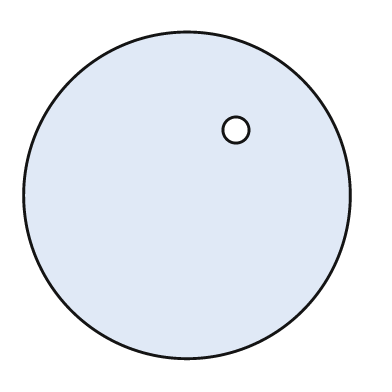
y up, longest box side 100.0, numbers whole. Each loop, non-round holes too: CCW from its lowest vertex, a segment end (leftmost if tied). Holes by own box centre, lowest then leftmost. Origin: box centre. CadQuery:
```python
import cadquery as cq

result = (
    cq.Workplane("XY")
    .moveTo(0.0, 0.0)
    .circle(50.0)
    .moveTo(15.0, 20.0)
    .circle(4.0)
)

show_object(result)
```